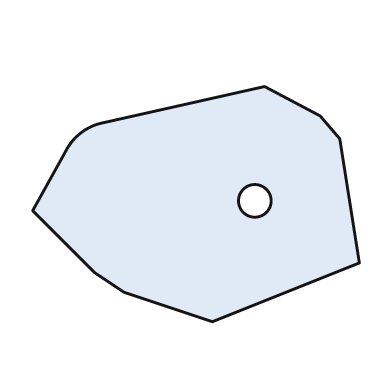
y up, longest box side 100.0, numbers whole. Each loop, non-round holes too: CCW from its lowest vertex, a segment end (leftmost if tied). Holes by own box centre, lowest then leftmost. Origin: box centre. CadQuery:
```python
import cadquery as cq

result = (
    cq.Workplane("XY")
    .moveTo(5.0, -36.0)
    .lineTo(50.0, -18.0)
    .lineTo(44.0, 20.0)
    .lineTo(38.0, 27.0)
    .lineTo(21.0, 36.0)
    .lineTo(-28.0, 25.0)
    .threePointArc((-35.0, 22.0), (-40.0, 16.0))
    .lineTo(-50.0, -2.0)
    .lineTo(-31.0, -21.0)
    .lineTo(-22.0, -27.0)
    .close()
    .moveTo(18.0, 1.0)
    .circle(5.0)
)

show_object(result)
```